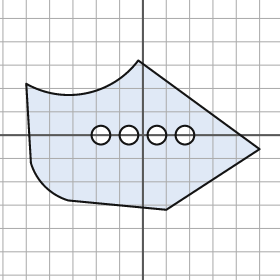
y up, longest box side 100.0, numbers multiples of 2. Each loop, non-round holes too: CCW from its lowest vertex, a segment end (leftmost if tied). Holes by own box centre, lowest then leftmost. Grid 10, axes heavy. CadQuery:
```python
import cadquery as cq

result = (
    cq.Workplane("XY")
    .moveTo(10.0, -32.0)
    .lineTo(50.0, -6.0)
    .lineTo(-2.0, 32.0)
    .threePointArc((-24.0, 18.0), (-50.0, 22.0))
    .lineTo(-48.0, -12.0)
    .threePointArc((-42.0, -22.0), (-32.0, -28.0))
    .close()
    .moveTo(-18.0, 0.0)
    .circle(4.0)
    .moveTo(-6.0, 0.0)
    .circle(4.0)
    .moveTo(6.0, 0.0)
    .circle(4.0)
    .moveTo(18.0, 0.0)
    .circle(4.0)
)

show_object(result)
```